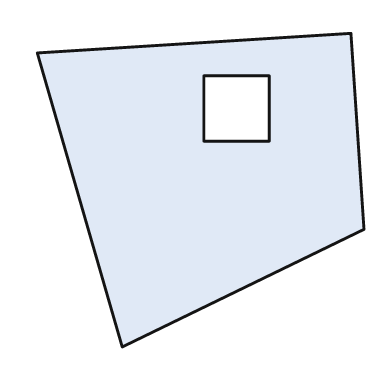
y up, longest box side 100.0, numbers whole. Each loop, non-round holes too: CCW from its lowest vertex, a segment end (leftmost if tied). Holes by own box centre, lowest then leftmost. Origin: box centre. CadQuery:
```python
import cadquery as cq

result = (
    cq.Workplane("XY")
    .moveTo(-24.0, -48.0)
    .lineTo(50.0, -12.0)
    .lineTo(46.0, 48.0)
    .lineTo(-50.0, 42.0)
    .close()
    .moveTo(1.0, 15.0)
    .lineTo(21.0, 15.0)
    .lineTo(21.0, 35.0)
    .lineTo(1.0, 35.0)
    .close()
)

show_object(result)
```